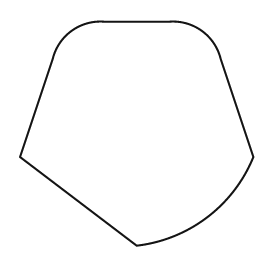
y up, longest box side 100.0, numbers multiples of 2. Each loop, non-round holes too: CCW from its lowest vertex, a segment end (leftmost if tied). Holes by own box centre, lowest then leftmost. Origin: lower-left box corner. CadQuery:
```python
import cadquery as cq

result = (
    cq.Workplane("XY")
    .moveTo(50.0, 0.0)
    .threePointArc((80.0, 12.0), (100.0, 38.0))
    .lineTo(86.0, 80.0)
    .threePointArc((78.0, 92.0), (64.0, 96.0))
    .lineTo(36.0, 96.0)
    .threePointArc((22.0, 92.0), (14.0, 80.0))
    .lineTo(0.0, 38.0)
    .close()
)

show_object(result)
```